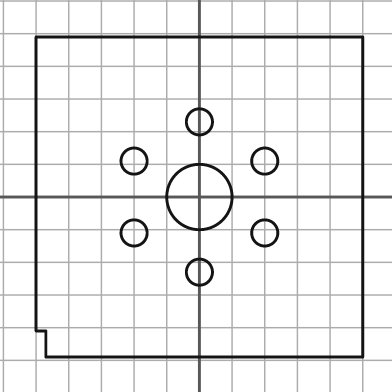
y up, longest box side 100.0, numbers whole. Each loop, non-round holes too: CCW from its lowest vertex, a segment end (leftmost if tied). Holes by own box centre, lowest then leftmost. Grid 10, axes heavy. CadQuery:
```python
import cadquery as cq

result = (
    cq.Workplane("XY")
    .moveTo(-47.0, -49.0)
    .lineTo(50.0, -49.0)
    .lineTo(50.0, 49.0)
    .lineTo(-50.0, 49.0)
    .lineTo(-50.0, -41.0)
    .lineTo(-47.0, -41.0)
    .close()
    .moveTo(0.0, -23.0)
    .circle(4.0)
    .moveTo(-20.0, -11.0)
    .circle(4.0)
    .moveTo(20.0, -11.0)
    .circle(4.0)
    .moveTo(0.0, 0.0)
    .circle(10.0)
    .moveTo(-20.0, 11.0)
    .circle(4.0)
    .moveTo(20.0, 11.0)
    .circle(4.0)
    .moveTo(0.0, 23.0)
    .circle(4.0)
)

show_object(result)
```